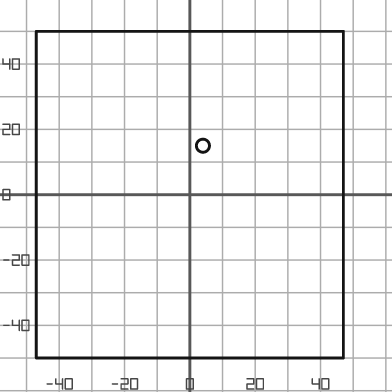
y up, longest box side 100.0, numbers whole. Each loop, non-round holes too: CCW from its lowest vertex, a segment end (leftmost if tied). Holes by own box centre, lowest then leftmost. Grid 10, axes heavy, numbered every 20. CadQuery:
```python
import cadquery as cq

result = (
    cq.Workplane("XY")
    .moveTo(-47.0, -50.0)
    .lineTo(47.0, -50.0)
    .lineTo(47.0, 50.0)
    .lineTo(-47.0, 50.0)
    .close()
    .moveTo(4.0, 15.0)
    .circle(2.0)
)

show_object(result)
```